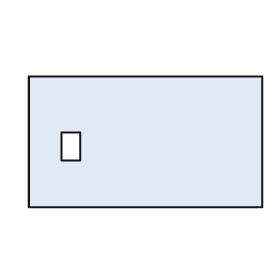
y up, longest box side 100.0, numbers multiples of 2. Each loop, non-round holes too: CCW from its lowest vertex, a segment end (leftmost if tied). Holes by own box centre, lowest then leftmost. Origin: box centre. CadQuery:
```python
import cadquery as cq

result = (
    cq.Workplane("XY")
    .moveTo(-50.0, -28.0)
    .lineTo(50.0, -28.0)
    .lineTo(50.0, 28.0)
    .lineTo(-50.0, 28.0)
    .close()
    .moveTo(-36.0, -8.0)
    .lineTo(-28.0, -8.0)
    .lineTo(-28.0, 4.0)
    .lineTo(-36.0, 4.0)
    .close()
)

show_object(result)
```